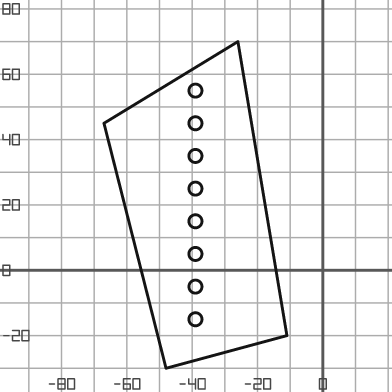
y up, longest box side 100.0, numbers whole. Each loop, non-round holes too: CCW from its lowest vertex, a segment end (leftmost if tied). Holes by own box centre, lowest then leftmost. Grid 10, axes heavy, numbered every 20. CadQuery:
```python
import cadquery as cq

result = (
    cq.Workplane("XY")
    .moveTo(-48.0, -30.0)
    .lineTo(-11.0, -20.0)
    .lineTo(-26.0, 70.0)
    .lineTo(-67.0, 45.0)
    .close()
    .moveTo(-39.0, -15.0)
    .circle(2.0)
    .moveTo(-39.0, -5.0)
    .circle(2.0)
    .moveTo(-39.0, 5.0)
    .circle(2.0)
    .moveTo(-39.0, 15.0)
    .circle(2.0)
    .moveTo(-39.0, 25.0)
    .circle(2.0)
    .moveTo(-39.0, 35.0)
    .circle(2.0)
    .moveTo(-39.0, 45.0)
    .circle(2.0)
    .moveTo(-39.0, 55.0)
    .circle(2.0)
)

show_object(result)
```